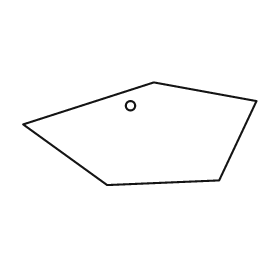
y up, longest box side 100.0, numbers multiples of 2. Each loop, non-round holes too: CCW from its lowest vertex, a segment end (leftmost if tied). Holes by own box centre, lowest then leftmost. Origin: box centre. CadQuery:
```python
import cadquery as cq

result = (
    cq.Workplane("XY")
    .moveTo(-14.0, -22.0)
    .lineTo(34.0, -20.0)
    .lineTo(50.0, 14.0)
    .lineTo(6.0, 22.0)
    .lineTo(-50.0, 4.0)
    .close()
    .moveTo(-4.0, 12.0)
    .circle(2.0)
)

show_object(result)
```